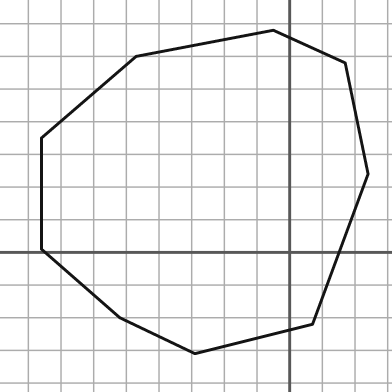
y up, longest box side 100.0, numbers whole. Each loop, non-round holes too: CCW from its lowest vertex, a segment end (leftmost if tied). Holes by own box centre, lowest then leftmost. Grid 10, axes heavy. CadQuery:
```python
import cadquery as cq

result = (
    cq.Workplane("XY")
    .moveTo(-29.0, -31.0)
    .lineTo(7.0, -22.0)
    .lineTo(24.0, 24.0)
    .lineTo(17.0, 58.0)
    .lineTo(-5.0, 68.0)
    .lineTo(-47.0, 60.0)
    .lineTo(-76.0, 35.0)
    .lineTo(-76.0, 1.0)
    .lineTo(-52.0, -20.0)
    .close()
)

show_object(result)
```